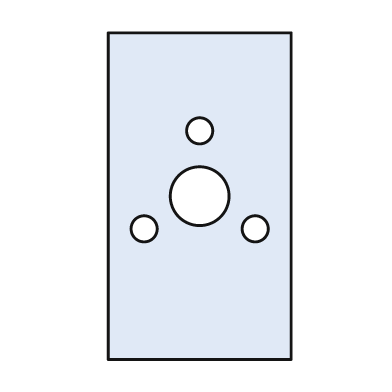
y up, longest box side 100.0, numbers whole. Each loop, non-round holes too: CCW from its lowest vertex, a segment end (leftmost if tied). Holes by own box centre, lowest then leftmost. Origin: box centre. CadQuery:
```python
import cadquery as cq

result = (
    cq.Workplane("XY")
    .moveTo(-28.0, -50.0)
    .lineTo(28.0, -50.0)
    .lineTo(28.0, 50.0)
    .lineTo(-28.0, 50.0)
    .close()
    .moveTo(-17.0, -10.0)
    .circle(4.0)
    .moveTo(17.0, -10.0)
    .circle(4.0)
    .moveTo(0.0, 0.0)
    .circle(9.0)
    .moveTo(0.0, 20.0)
    .circle(4.0)
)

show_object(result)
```